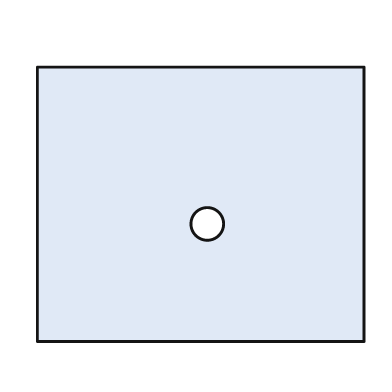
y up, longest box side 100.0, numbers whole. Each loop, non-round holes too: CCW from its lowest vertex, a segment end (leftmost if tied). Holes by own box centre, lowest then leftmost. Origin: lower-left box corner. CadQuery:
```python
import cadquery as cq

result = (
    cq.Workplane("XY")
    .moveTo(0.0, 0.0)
    .lineTo(100.0, 0.0)
    .lineTo(100.0, 84.0)
    .lineTo(0.0, 84.0)
    .close()
    .moveTo(52.0, 36.0)
    .circle(5.0)
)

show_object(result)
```